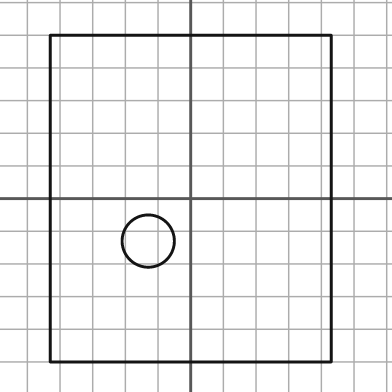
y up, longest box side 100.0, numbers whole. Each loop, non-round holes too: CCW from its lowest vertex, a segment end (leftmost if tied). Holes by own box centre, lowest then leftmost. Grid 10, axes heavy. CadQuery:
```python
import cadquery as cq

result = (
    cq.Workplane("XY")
    .moveTo(-43.0, -50.0)
    .lineTo(43.0, -50.0)
    .lineTo(43.0, 50.0)
    .lineTo(-43.0, 50.0)
    .close()
    .moveTo(-13.0, -13.0)
    .circle(8.0)
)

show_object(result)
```